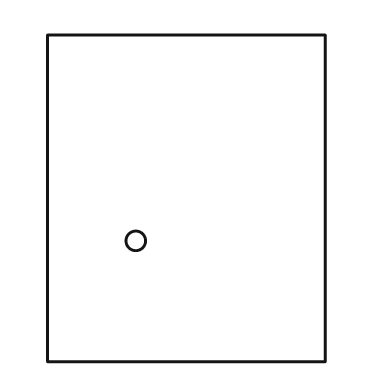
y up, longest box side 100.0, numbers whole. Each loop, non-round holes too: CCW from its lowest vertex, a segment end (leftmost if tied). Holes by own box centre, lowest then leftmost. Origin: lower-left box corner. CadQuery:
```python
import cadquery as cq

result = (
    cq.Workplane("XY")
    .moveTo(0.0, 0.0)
    .lineTo(85.0, 0.0)
    .lineTo(85.0, 100.0)
    .lineTo(0.0, 100.0)
    .close()
    .moveTo(27.0, 37.0)
    .circle(3.0)
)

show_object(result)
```